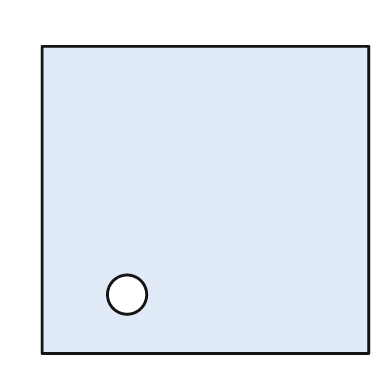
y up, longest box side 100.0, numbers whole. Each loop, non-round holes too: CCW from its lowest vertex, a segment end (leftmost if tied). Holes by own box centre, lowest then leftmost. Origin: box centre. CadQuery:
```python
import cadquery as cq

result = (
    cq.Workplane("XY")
    .moveTo(-50.0, -47.0)
    .lineTo(50.0, -47.0)
    .lineTo(50.0, 47.0)
    .lineTo(-50.0, 47.0)
    .close()
    .moveTo(-24.0, -29.0)
    .circle(6.0)
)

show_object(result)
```